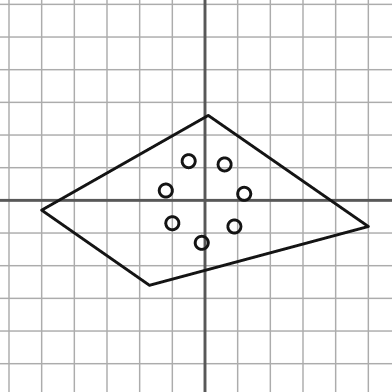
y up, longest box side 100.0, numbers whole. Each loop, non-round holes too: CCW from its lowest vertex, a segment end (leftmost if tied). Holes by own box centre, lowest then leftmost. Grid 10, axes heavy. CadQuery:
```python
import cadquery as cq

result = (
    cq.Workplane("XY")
    .moveTo(-17.0, -26.0)
    .lineTo(50.0, -8.0)
    .lineTo(1.0, 26.0)
    .lineTo(-50.0, -3.0)
    .close()
    .moveTo(-1.0, -13.0)
    .circle(2.0)
    .moveTo(9.0, -8.0)
    .circle(2.0)
    .moveTo(-10.0, -7.0)
    .circle(2.0)
    .moveTo(12.0, 2.0)
    .circle(2.0)
    .moveTo(-12.0, 3.0)
    .circle(2.0)
    .moveTo(6.0, 11.0)
    .circle(2.0)
    .moveTo(-5.0, 12.0)
    .circle(2.0)
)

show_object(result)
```